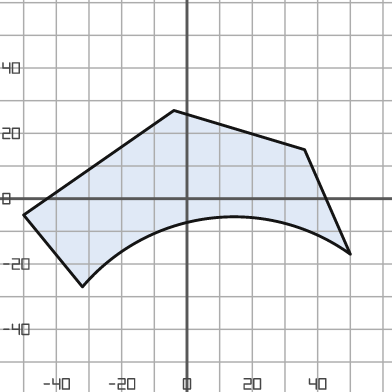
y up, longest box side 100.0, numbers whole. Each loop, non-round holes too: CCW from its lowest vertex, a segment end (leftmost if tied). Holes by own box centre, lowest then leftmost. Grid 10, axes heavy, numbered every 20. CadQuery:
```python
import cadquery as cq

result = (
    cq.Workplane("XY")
    .moveTo(-32.0, -27.0)
    .threePointArc((7.0, -6.0), (50.0, -17.0))
    .lineTo(36.0, 15.0)
    .lineTo(-4.0, 27.0)
    .lineTo(-50.0, -5.0)
    .close()
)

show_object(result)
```